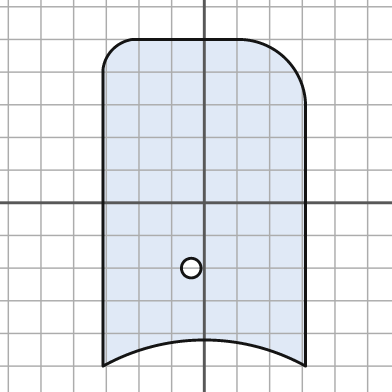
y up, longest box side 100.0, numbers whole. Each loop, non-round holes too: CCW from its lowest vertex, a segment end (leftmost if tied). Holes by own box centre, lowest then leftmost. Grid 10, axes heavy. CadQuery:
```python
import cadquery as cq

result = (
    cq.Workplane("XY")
    .moveTo(-31.0, -50.0)
    .threePointArc((0.0, -42.0), (31.0, -50.0))
    .lineTo(31.0, 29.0)
    .threePointArc((25.0, 44.0), (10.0, 50.0))
    .lineTo(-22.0, 50.0)
    .threePointArc((-28.0, 47.0), (-31.0, 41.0))
    .close()
    .moveTo(-4.0, -20.0)
    .circle(3.0)
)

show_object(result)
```